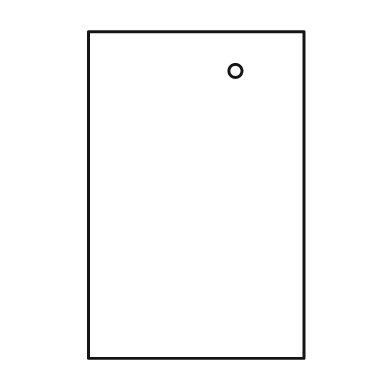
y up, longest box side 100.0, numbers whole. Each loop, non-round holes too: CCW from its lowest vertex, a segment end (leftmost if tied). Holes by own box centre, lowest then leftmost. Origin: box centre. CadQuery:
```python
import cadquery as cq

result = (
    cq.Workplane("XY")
    .moveTo(-33.0, -50.0)
    .lineTo(33.0, -50.0)
    .lineTo(33.0, 50.0)
    .lineTo(-33.0, 50.0)
    .close()
    .moveTo(12.0, 38.0)
    .circle(2.0)
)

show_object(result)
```